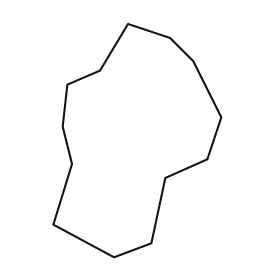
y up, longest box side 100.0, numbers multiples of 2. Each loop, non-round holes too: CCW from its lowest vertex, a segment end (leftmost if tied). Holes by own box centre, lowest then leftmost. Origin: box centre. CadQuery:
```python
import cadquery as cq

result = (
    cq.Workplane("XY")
    .moveTo(-10.0, -50.0)
    .lineTo(6.0, -44.0)
    .lineTo(12.0, -16.0)
    .lineTo(30.0, -8.0)
    .lineTo(36.0, 10.0)
    .lineTo(24.0, 34.0)
    .lineTo(14.0, 44.0)
    .lineTo(-4.0, 50.0)
    .lineTo(-16.0, 30.0)
    .lineTo(-30.0, 24.0)
    .lineTo(-32.0, 6.0)
    .lineTo(-28.0, -10.0)
    .lineTo(-36.0, -36.0)
    .close()
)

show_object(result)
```